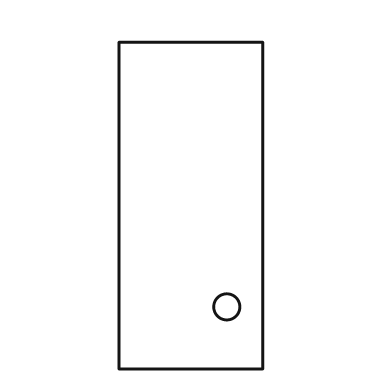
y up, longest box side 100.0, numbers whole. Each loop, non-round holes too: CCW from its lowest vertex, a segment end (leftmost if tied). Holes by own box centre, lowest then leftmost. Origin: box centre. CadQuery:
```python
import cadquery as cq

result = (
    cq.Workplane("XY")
    .moveTo(-22.0, -50.0)
    .lineTo(22.0, -50.0)
    .lineTo(22.0, 50.0)
    .lineTo(-22.0, 50.0)
    .close()
    .moveTo(11.0, -31.0)
    .circle(4.0)
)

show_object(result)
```